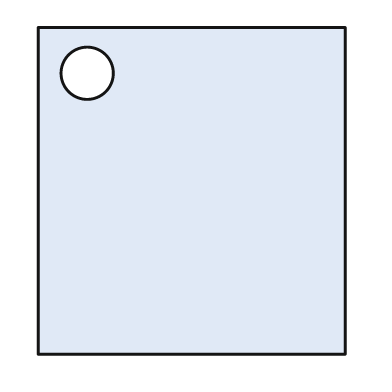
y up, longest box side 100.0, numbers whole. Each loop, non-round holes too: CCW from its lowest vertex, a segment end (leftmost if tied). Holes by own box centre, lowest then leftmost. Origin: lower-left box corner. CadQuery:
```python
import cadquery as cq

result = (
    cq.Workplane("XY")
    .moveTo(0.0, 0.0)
    .lineTo(94.0, 0.0)
    .lineTo(94.0, 100.0)
    .lineTo(0.0, 100.0)
    .close()
    .moveTo(15.0, 86.0)
    .circle(8.0)
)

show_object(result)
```